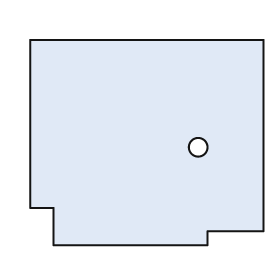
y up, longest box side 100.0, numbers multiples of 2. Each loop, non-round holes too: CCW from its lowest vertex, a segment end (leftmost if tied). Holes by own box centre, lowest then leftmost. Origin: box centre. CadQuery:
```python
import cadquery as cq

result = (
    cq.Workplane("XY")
    .moveTo(-40.0, -44.0)
    .lineTo(26.0, -44.0)
    .lineTo(26.0, -38.0)
    .lineTo(50.0, -38.0)
    .lineTo(50.0, 44.0)
    .lineTo(-50.0, 44.0)
    .lineTo(-50.0, -28.0)
    .lineTo(-40.0, -28.0)
    .close()
    .moveTo(22.0, -2.0)
    .circle(4.0)
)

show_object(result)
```